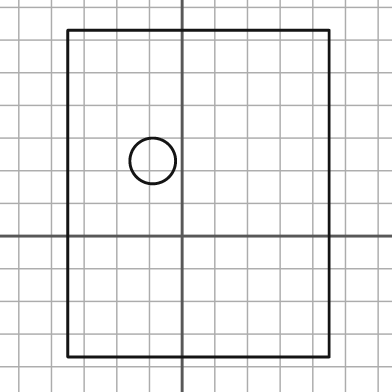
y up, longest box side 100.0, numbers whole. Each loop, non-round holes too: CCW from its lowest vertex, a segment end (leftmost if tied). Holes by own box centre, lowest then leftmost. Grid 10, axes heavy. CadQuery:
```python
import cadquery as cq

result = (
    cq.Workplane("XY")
    .moveTo(-35.0, -37.0)
    .lineTo(45.0, -37.0)
    .lineTo(45.0, 63.0)
    .lineTo(-35.0, 63.0)
    .close()
    .moveTo(-9.0, 23.0)
    .circle(7.0)
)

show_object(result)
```